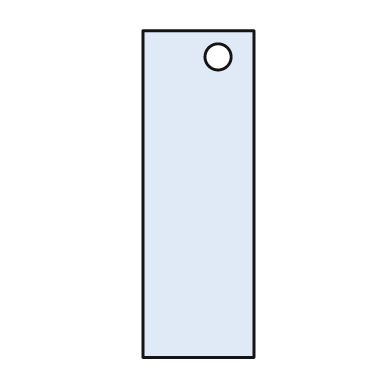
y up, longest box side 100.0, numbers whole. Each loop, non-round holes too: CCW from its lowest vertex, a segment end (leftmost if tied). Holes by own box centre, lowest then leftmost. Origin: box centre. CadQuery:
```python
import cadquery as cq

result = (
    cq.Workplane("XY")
    .moveTo(-17.0, -50.0)
    .lineTo(17.0, -50.0)
    .lineTo(17.0, 50.0)
    .lineTo(-17.0, 50.0)
    .close()
    .moveTo(6.0, 42.0)
    .circle(4.0)
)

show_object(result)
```